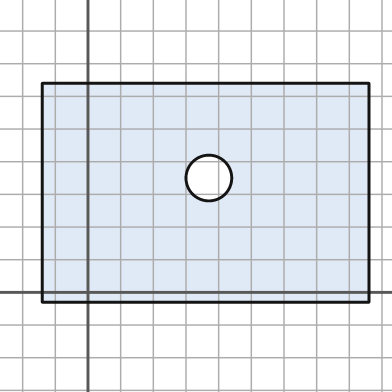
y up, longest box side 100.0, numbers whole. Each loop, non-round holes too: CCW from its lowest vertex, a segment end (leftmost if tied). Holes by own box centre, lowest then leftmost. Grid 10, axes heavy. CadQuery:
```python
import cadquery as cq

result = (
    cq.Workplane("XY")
    .moveTo(-14.0, -3.0)
    .lineTo(86.0, -3.0)
    .lineTo(86.0, 64.0)
    .lineTo(-14.0, 64.0)
    .close()
    .moveTo(37.0, 35.0)
    .circle(7.0)
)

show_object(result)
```